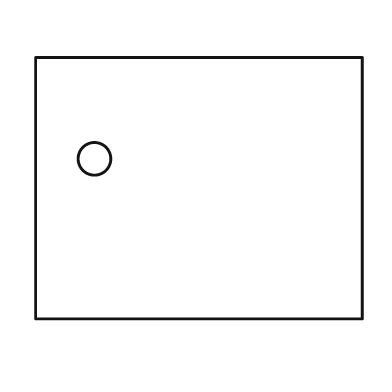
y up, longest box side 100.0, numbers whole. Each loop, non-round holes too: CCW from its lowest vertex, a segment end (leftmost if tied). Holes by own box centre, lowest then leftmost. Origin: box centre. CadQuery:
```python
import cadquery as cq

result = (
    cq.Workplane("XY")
    .moveTo(-50.0, -40.0)
    .lineTo(50.0, -40.0)
    .lineTo(50.0, 40.0)
    .lineTo(-50.0, 40.0)
    .close()
    .moveTo(-32.0, 9.0)
    .circle(5.0)
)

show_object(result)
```